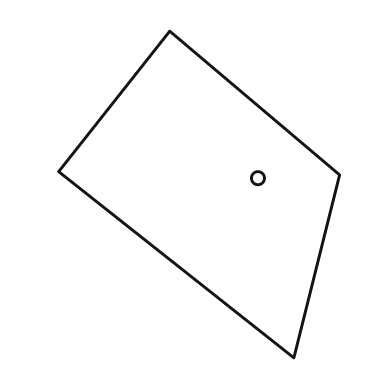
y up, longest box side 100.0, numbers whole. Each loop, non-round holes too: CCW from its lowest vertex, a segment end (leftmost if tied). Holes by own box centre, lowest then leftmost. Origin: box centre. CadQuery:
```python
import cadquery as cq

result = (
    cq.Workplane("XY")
    .moveTo(29.0, -50.0)
    .lineTo(43.0, 6.0)
    .lineTo(-9.0, 50.0)
    .lineTo(-43.0, 7.0)
    .close()
    .moveTo(18.0, 5.0)
    .circle(2.0)
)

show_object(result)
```